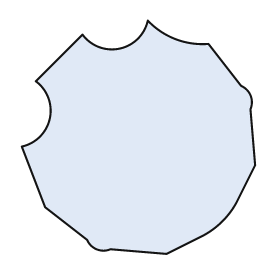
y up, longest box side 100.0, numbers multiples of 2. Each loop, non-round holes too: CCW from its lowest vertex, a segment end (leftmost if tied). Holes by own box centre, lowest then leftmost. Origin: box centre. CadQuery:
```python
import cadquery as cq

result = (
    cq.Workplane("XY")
    .moveTo(12.0, -50.0)
    .lineTo(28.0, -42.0)
    .threePointArc((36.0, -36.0), (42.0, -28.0))
    .lineTo(50.0, -12.0)
    .lineTo(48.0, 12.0)
    .threePointArc((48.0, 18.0), (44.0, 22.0))
    .lineTo(30.0, 40.0)
    .threePointArc((16.0, 42.0), (4.0, 50.0))
    .threePointArc((-8.0, 38.0), (-24.0, 44.0))
    .lineTo(-44.0, 24.0)
    .threePointArc((-38.0, 8.0), (-50.0, -4.0))
    .lineTo(-40.0, -30.0)
    .lineTo(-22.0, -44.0)
    .threePointArc((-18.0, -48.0), (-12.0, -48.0))
    .close()
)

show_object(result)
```